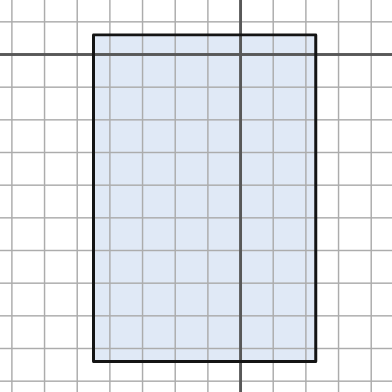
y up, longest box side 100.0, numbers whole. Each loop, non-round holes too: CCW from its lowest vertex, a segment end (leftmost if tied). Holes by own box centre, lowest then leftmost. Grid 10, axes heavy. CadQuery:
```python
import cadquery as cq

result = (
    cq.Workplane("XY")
    .moveTo(-45.0, -94.0)
    .lineTo(23.0, -94.0)
    .lineTo(23.0, 6.0)
    .lineTo(-45.0, 6.0)
    .close()
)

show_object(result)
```